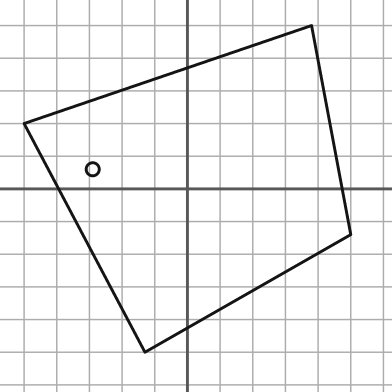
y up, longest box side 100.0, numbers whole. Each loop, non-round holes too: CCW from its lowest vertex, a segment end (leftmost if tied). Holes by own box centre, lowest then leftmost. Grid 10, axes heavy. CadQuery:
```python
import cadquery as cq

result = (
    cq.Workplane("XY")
    .moveTo(-13.0, -50.0)
    .lineTo(50.0, -14.0)
    .lineTo(38.0, 50.0)
    .lineTo(-50.0, 20.0)
    .close()
    .moveTo(-29.0, 6.0)
    .circle(2.0)
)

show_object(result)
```